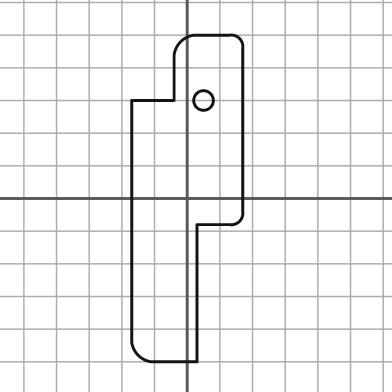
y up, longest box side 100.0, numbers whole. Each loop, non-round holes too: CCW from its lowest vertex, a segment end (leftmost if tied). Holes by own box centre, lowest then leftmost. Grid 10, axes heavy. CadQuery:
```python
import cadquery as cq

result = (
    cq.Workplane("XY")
    .moveTo(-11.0, -50.0)
    .lineTo(3.0, -50.0)
    .lineTo(3.0, -8.0)
    .lineTo(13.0, -8.0)
    .threePointArc((16.0, -7.0), (17.0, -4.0))
    .lineTo(17.0, 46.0)
    .threePointArc((16.0, 49.0), (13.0, 50.0))
    .lineTo(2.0, 50.0)
    .threePointArc((-2.0, 48.0), (-4.0, 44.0))
    .lineTo(-4.0, 30.0)
    .lineTo(-17.0, 30.0)
    .lineTo(-17.0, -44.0)
    .threePointArc((-15.0, -48.0), (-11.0, -50.0))
    .close()
    .moveTo(5.0, 30.0)
    .circle(3.0)
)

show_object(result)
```